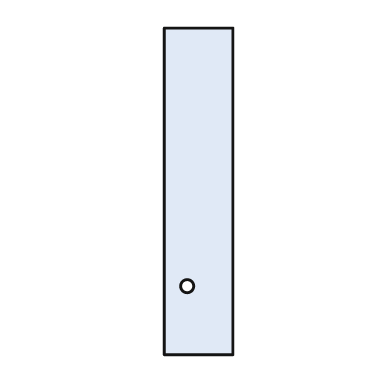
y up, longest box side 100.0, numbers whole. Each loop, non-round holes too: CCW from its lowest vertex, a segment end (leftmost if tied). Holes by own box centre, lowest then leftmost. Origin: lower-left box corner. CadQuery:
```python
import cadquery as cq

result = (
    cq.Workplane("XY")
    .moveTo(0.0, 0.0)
    .lineTo(21.0, 0.0)
    .lineTo(21.0, 100.0)
    .lineTo(0.0, 100.0)
    .close()
    .moveTo(7.0, 21.0)
    .circle(2.0)
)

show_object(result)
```